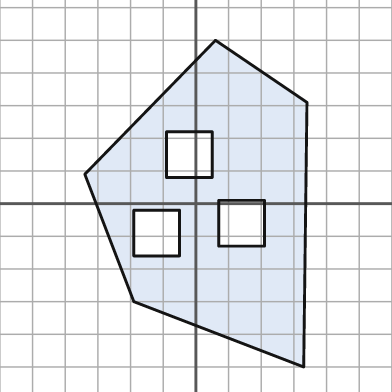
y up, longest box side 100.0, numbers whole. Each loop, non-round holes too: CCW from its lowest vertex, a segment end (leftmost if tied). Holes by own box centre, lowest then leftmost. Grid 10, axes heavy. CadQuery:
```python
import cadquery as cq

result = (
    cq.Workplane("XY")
    .moveTo(33.0, -50.0)
    .lineTo(34.0, 31.0)
    .lineTo(6.0, 50.0)
    .lineTo(-34.0, 9.0)
    .lineTo(-19.0, -30.0)
    .close()
    .moveTo(-19.0, -16.0)
    .lineTo(-5.0, -16.0)
    .lineTo(-5.0, -2.0)
    .lineTo(-19.0, -2.0)
    .close()
    .moveTo(7.0, -13.0)
    .lineTo(21.0, -13.0)
    .lineTo(21.0, 1.0)
    .lineTo(7.0, 1.0)
    .close()
    .moveTo(-9.0, 8.0)
    .lineTo(5.0, 8.0)
    .lineTo(5.0, 22.0)
    .lineTo(-9.0, 22.0)
    .close()
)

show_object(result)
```